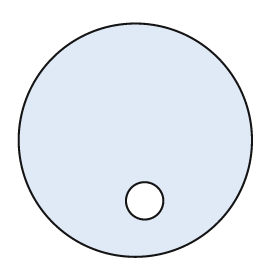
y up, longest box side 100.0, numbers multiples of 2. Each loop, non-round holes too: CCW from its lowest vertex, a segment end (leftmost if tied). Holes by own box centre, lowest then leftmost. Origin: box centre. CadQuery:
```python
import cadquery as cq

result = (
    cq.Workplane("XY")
    .moveTo(0.0, 0.0)
    .circle(50.0)
    .moveTo(4.0, -26.0)
    .circle(8.0)
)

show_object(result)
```